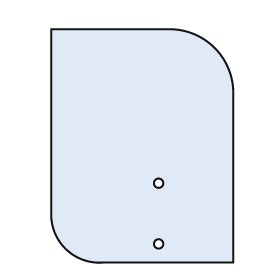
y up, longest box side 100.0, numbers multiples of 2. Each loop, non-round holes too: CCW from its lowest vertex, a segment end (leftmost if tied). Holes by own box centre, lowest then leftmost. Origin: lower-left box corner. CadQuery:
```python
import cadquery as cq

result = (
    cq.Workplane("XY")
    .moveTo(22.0, 0.0)
    .lineTo(78.0, 0.0)
    .lineTo(78.0, 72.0)
    .threePointArc((70.0, 92.0), (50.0, 100.0))
    .lineTo(0.0, 100.0)
    .lineTo(0.0, 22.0)
    .threePointArc((6.0, 6.0), (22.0, 0.0))
    .close()
    .moveTo(46.0, 8.0)
    .circle(2.0)
    .moveTo(46.0, 34.0)
    .circle(2.0)
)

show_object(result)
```